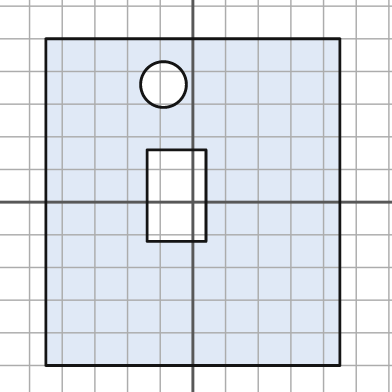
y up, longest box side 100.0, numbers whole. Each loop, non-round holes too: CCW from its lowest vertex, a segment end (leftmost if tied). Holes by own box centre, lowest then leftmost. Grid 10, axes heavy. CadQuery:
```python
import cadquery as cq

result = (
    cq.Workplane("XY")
    .moveTo(-45.0, -50.0)
    .lineTo(45.0, -50.0)
    .lineTo(45.0, 50.0)
    .lineTo(-45.0, 50.0)
    .close()
    .moveTo(-14.0, -12.0)
    .lineTo(4.0, -12.0)
    .lineTo(4.0, 16.0)
    .lineTo(-14.0, 16.0)
    .close()
    .moveTo(-9.0, 36.0)
    .circle(7.0)
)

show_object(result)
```